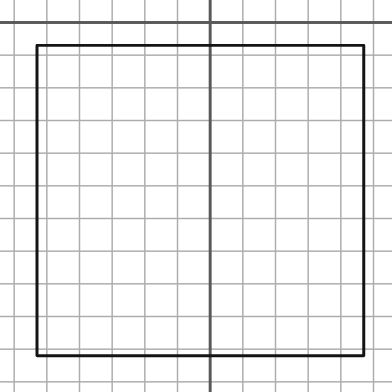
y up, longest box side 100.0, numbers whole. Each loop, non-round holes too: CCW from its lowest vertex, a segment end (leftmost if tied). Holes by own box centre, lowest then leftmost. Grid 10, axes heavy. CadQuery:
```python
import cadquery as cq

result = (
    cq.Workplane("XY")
    .moveTo(-53.0, -102.0)
    .lineTo(47.0, -102.0)
    .lineTo(47.0, -7.0)
    .lineTo(-53.0, -7.0)
    .close()
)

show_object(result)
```